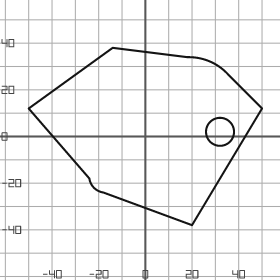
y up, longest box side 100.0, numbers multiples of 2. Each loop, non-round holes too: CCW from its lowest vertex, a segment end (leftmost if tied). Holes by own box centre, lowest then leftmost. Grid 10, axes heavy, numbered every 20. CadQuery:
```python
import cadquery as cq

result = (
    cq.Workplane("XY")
    .moveTo(20.0, -38.0)
    .lineTo(50.0, 12.0)
    .lineTo(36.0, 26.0)
    .threePointArc((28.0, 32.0), (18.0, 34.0))
    .lineTo(-14.0, 38.0)
    .lineTo(-50.0, 12.0)
    .lineTo(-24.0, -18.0)
    .threePointArc((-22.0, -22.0), (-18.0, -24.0))
    .close()
    .moveTo(32.0, 2.0)
    .circle(6.0)
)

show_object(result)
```